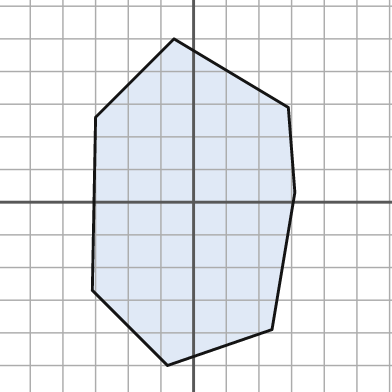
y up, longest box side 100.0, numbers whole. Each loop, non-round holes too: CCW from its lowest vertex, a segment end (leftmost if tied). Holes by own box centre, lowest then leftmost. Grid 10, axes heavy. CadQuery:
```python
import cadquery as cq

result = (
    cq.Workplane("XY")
    .moveTo(-8.0, -50.0)
    .lineTo(24.0, -39.0)
    .lineTo(31.0, 3.0)
    .lineTo(29.0, 29.0)
    .lineTo(-6.0, 50.0)
    .lineTo(-30.0, 26.0)
    .lineTo(-31.0, -27.0)
    .close()
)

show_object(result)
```